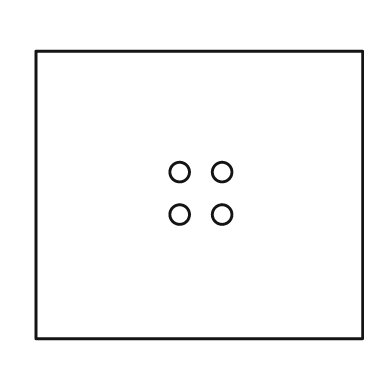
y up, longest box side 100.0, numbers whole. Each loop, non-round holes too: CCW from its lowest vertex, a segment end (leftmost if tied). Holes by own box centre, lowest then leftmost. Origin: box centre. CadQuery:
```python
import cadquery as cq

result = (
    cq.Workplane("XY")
    .moveTo(-50.0, -44.0)
    .lineTo(50.0, -44.0)
    .lineTo(50.0, 44.0)
    .lineTo(-50.0, 44.0)
    .close()
    .moveTo(-6.0, -6.0)
    .circle(3.0)
    .moveTo(7.0, -6.0)
    .circle(3.0)
    .moveTo(-6.0, 7.0)
    .circle(3.0)
    .moveTo(7.0, 7.0)
    .circle(3.0)
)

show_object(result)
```